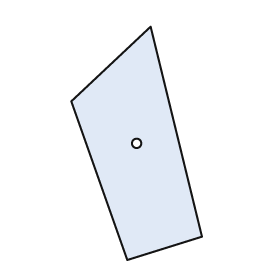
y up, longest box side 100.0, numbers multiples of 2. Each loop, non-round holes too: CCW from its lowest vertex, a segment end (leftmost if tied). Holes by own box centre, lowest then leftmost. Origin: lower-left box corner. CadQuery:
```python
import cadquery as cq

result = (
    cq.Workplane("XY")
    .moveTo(24.0, 0.0)
    .lineTo(56.0, 10.0)
    .lineTo(34.0, 100.0)
    .lineTo(0.0, 68.0)
    .close()
    .moveTo(28.0, 50.0)
    .circle(2.0)
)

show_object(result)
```